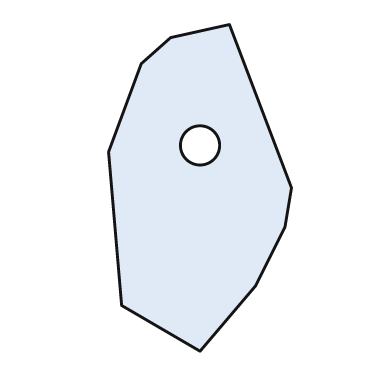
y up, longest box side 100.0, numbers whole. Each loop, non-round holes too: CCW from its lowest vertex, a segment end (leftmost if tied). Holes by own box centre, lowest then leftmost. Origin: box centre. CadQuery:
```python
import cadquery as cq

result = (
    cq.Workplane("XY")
    .moveTo(0.0, -50.0)
    .lineTo(17.0, -30.0)
    .lineTo(26.0, -12.0)
    .lineTo(28.0, 0.0)
    .lineTo(9.0, 50.0)
    .lineTo(-9.0, 46.0)
    .lineTo(-18.0, 38.0)
    .lineTo(-28.0, 11.0)
    .lineTo(-24.0, -36.0)
    .close()
    .moveTo(0.0, 13.0)
    .circle(6.0)
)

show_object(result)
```